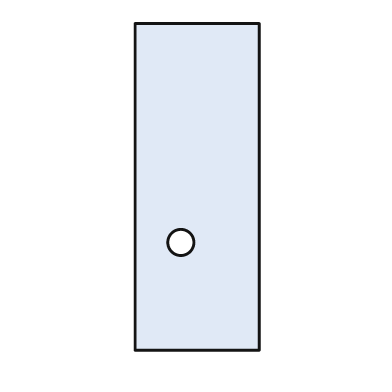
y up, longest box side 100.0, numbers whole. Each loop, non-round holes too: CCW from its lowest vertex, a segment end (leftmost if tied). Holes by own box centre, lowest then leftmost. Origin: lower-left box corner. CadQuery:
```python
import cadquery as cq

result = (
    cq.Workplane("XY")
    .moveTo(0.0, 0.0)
    .lineTo(38.0, 0.0)
    .lineTo(38.0, 100.0)
    .lineTo(0.0, 100.0)
    .close()
    .moveTo(14.0, 33.0)
    .circle(4.0)
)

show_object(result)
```